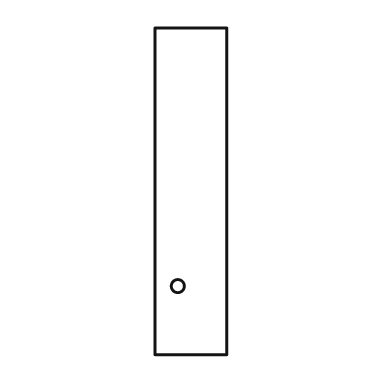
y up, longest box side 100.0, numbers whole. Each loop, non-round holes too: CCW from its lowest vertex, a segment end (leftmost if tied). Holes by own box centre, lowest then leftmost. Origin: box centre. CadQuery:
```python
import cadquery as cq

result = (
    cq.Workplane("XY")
    .moveTo(-11.0, -50.0)
    .lineTo(11.0, -50.0)
    .lineTo(11.0, 50.0)
    .lineTo(-11.0, 50.0)
    .close()
    .moveTo(-4.0, -29.0)
    .circle(2.0)
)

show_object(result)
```